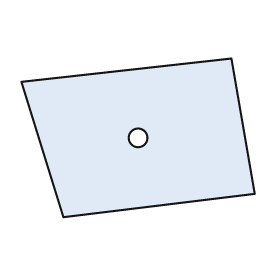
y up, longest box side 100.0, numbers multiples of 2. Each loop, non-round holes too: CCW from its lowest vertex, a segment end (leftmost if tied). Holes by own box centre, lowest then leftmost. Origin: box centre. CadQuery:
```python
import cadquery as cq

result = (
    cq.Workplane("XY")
    .moveTo(-32.0, -34.0)
    .lineTo(50.0, -24.0)
    .lineTo(40.0, 34.0)
    .lineTo(-50.0, 24.0)
    .close()
    .moveTo(0.0, 0.0)
    .circle(4.0)
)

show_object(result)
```